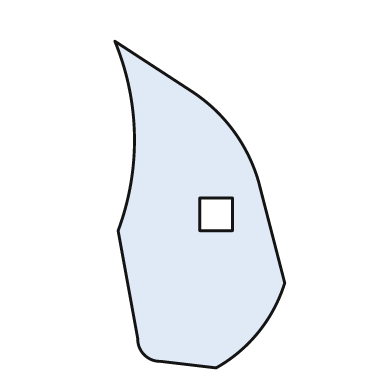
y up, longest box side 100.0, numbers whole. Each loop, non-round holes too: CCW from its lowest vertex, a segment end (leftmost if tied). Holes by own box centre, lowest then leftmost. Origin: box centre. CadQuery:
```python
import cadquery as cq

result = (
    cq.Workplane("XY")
    .moveTo(5.0, -50.0)
    .threePointArc((18.0, -39.0), (26.0, -24.0))
    .lineTo(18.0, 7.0)
    .threePointArc((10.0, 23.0), (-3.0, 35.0))
    .lineTo(-26.0, 50.0)
    .threePointArc((-20.0, 21.0), (-25.0, -8.0))
    .lineTo(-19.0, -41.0)
    .threePointArc((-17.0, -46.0), (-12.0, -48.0))
    .close()
    .moveTo(0.0, -8.0)
    .lineTo(10.0, -8.0)
    .lineTo(10.0, 2.0)
    .lineTo(0.0, 2.0)
    .close()
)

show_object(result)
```